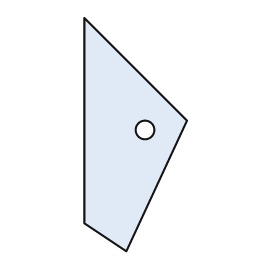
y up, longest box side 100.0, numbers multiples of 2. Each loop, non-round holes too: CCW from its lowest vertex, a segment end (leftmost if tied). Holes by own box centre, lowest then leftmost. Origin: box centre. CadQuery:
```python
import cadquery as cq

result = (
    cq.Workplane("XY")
    .moveTo(-4.0, -50.0)
    .lineTo(22.0, 6.0)
    .lineTo(-22.0, 50.0)
    .lineTo(-22.0, -38.0)
    .close()
    .moveTo(4.0, 2.0)
    .circle(4.0)
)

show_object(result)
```